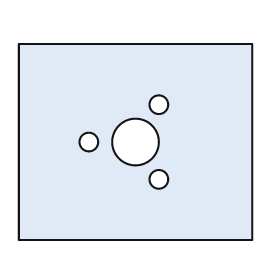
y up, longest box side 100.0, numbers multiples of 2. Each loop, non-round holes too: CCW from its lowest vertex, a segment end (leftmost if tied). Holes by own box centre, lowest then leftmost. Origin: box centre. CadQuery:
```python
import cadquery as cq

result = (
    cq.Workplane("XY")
    .moveTo(-50.0, -42.0)
    .lineTo(50.0, -42.0)
    .lineTo(50.0, 42.0)
    .lineTo(-50.0, 42.0)
    .close()
    .moveTo(10.0, -16.0)
    .circle(4.0)
    .moveTo(-20.0, 0.0)
    .circle(4.0)
    .moveTo(0.0, 0.0)
    .circle(10.0)
    .moveTo(10.0, 16.0)
    .circle(4.0)
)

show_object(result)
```